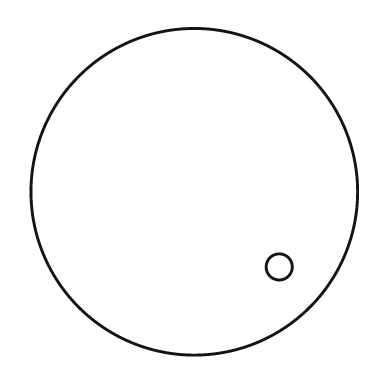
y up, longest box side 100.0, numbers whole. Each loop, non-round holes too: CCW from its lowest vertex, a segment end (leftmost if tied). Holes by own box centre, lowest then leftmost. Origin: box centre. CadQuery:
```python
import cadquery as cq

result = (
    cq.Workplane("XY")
    .moveTo(0.0, 0.0)
    .circle(50.0)
    .moveTo(26.0, -23.0)
    .circle(4.0)
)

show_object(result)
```